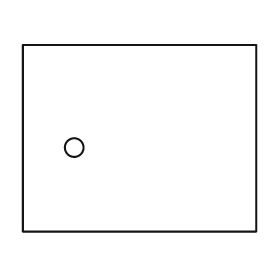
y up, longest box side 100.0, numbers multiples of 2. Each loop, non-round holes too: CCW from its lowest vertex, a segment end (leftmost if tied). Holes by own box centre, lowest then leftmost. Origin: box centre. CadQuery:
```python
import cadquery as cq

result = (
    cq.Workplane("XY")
    .moveTo(-50.0, -40.0)
    .lineTo(50.0, -40.0)
    .lineTo(50.0, 40.0)
    .lineTo(-50.0, 40.0)
    .close()
    .moveTo(-28.0, -4.0)
    .circle(4.0)
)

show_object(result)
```